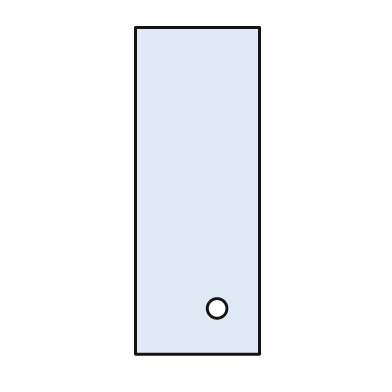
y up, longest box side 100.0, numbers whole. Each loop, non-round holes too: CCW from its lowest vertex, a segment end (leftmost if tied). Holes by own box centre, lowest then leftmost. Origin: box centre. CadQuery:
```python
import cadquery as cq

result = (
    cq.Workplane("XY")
    .moveTo(-19.0, -50.0)
    .lineTo(19.0, -50.0)
    .lineTo(19.0, 50.0)
    .lineTo(-19.0, 50.0)
    .close()
    .moveTo(6.0, -36.0)
    .circle(3.0)
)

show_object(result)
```